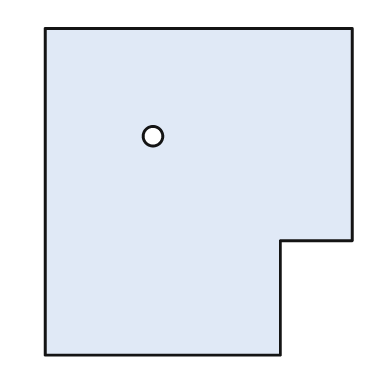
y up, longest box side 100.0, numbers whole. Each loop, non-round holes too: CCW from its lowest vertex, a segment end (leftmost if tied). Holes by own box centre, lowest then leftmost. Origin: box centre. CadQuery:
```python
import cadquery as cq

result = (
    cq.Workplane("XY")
    .moveTo(-47.0, -50.0)
    .lineTo(25.0, -50.0)
    .lineTo(25.0, -15.0)
    .lineTo(47.0, -15.0)
    .lineTo(47.0, 50.0)
    .lineTo(-47.0, 50.0)
    .close()
    .moveTo(-14.0, 17.0)
    .circle(3.0)
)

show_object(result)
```